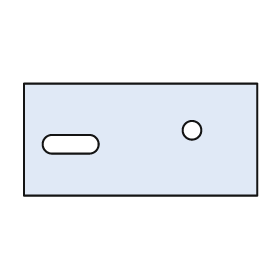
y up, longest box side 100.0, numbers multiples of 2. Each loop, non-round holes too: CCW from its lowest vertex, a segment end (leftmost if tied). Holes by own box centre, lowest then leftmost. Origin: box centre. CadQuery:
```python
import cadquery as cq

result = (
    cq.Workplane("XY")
    .moveTo(-50.0, -24.0)
    .lineTo(50.0, -24.0)
    .lineTo(50.0, 24.0)
    .lineTo(-50.0, 24.0)
    .close()
    .moveTo(-38.0, -6.0)
    .lineTo(-22.0, -6.0)
    .threePointArc((-18.0, -2.0), (-22.0, 2.0))
    .lineTo(-38.0, 2.0)
    .threePointArc((-42.0, -2.0), (-38.0, -6.0))
    .close()
    .moveTo(22.0, 4.0)
    .circle(4.0)
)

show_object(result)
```